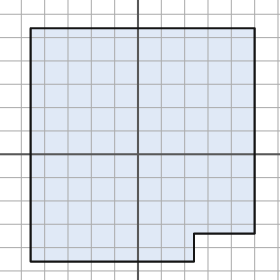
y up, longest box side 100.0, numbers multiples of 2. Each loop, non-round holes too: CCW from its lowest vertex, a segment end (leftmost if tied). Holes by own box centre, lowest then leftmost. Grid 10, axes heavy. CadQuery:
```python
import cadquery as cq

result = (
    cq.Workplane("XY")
    .moveTo(-46.0, -46.0)
    .lineTo(24.0, -46.0)
    .lineTo(24.0, -34.0)
    .lineTo(50.0, -34.0)
    .lineTo(50.0, 54.0)
    .lineTo(-46.0, 54.0)
    .close()
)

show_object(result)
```